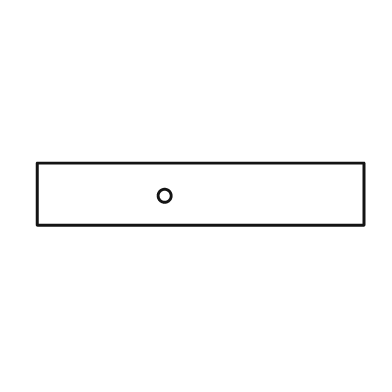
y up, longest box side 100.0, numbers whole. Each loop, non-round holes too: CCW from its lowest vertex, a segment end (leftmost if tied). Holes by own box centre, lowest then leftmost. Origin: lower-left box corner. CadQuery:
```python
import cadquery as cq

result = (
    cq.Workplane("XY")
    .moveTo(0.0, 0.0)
    .lineTo(100.0, 0.0)
    .lineTo(100.0, 19.0)
    .lineTo(0.0, 19.0)
    .close()
    .moveTo(39.0, 9.0)
    .circle(2.0)
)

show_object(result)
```